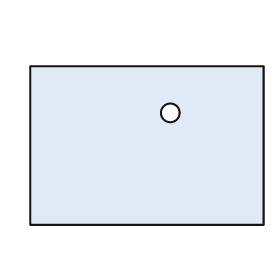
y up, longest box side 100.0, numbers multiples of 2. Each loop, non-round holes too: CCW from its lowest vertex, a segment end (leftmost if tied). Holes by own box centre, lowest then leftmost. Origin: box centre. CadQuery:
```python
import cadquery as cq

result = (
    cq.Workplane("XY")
    .moveTo(-50.0, -34.0)
    .lineTo(50.0, -34.0)
    .lineTo(50.0, 34.0)
    .lineTo(-50.0, 34.0)
    .close()
    .moveTo(10.0, 14.0)
    .circle(4.0)
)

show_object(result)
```